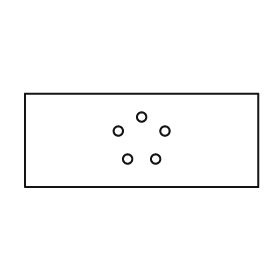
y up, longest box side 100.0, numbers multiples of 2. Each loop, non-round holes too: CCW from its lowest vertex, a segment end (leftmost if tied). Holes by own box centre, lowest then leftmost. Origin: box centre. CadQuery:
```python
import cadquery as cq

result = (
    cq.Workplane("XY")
    .moveTo(-50.0, -20.0)
    .lineTo(50.0, -20.0)
    .lineTo(50.0, 20.0)
    .lineTo(-50.0, 20.0)
    .close()
    .moveTo(-6.0, -8.0)
    .circle(2.0)
    .moveTo(6.0, -8.0)
    .circle(2.0)
    .moveTo(-10.0, 4.0)
    .circle(2.0)
    .moveTo(10.0, 4.0)
    .circle(2.0)
    .moveTo(0.0, 10.0)
    .circle(2.0)
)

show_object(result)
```